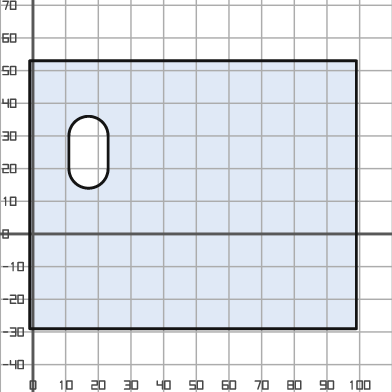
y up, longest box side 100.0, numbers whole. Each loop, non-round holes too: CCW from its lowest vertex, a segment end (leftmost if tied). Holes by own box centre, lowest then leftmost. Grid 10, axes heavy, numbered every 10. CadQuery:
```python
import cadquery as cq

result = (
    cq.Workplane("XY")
    .moveTo(-1.0, -29.0)
    .lineTo(99.0, -29.0)
    .lineTo(99.0, 53.0)
    .lineTo(-1.0, 53.0)
    .close()
    .moveTo(11.0, 20.0)
    .threePointArc((17.0, 14.0), (23.0, 20.0))
    .lineTo(23.0, 30.0)
    .threePointArc((17.0, 36.0), (11.0, 30.0))
    .close()
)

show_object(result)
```